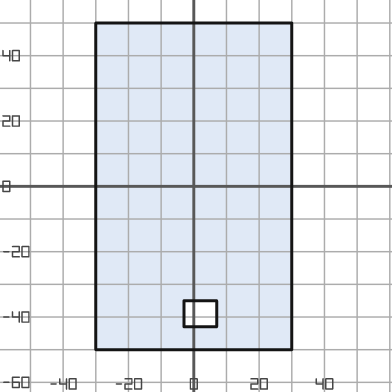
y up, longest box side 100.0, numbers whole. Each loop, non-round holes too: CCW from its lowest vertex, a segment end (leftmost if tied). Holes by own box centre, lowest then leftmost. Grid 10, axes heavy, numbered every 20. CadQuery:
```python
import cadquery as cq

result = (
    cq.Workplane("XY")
    .moveTo(-30.0, -50.0)
    .lineTo(30.0, -50.0)
    .lineTo(30.0, 50.0)
    .lineTo(-30.0, 50.0)
    .close()
    .moveTo(-3.0, -43.0)
    .lineTo(7.0, -43.0)
    .lineTo(7.0, -35.0)
    .lineTo(-3.0, -35.0)
    .close()
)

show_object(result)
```